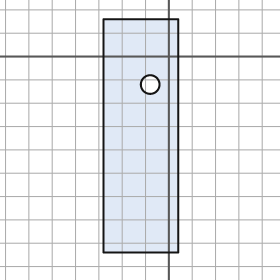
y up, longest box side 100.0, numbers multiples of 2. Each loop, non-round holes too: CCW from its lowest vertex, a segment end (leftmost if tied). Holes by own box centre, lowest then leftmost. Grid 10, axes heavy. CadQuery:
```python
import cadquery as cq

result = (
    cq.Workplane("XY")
    .moveTo(-28.0, -84.0)
    .lineTo(4.0, -84.0)
    .lineTo(4.0, 16.0)
    .lineTo(-28.0, 16.0)
    .close()
    .moveTo(-8.0, -12.0)
    .circle(4.0)
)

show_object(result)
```